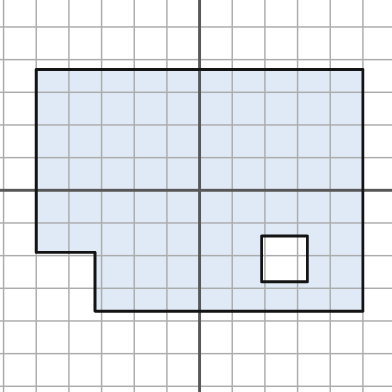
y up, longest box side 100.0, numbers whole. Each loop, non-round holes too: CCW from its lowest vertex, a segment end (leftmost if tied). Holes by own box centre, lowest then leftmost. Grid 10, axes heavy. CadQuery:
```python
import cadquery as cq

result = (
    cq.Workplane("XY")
    .moveTo(-32.0, -37.0)
    .lineTo(50.0, -37.0)
    .lineTo(50.0, 37.0)
    .lineTo(-50.0, 37.0)
    .lineTo(-50.0, -19.0)
    .lineTo(-32.0, -19.0)
    .close()
    .moveTo(19.0, -28.0)
    .lineTo(33.0, -28.0)
    .lineTo(33.0, -14.0)
    .lineTo(19.0, -14.0)
    .close()
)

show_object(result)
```